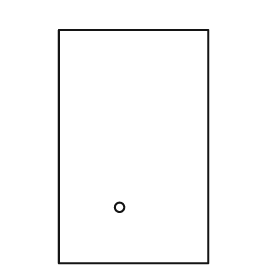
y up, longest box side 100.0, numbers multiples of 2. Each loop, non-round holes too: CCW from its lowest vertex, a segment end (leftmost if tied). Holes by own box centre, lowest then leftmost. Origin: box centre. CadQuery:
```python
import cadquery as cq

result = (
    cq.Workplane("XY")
    .moveTo(-32.0, -50.0)
    .lineTo(32.0, -50.0)
    .lineTo(32.0, 50.0)
    .lineTo(-32.0, 50.0)
    .close()
    .moveTo(-6.0, -26.0)
    .circle(2.0)
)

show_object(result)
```